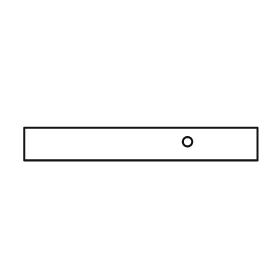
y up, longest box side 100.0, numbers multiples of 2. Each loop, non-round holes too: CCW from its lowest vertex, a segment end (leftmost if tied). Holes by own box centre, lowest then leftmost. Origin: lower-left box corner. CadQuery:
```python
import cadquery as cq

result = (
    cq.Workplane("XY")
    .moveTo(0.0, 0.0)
    .lineTo(100.0, 0.0)
    .lineTo(100.0, 14.0)
    .lineTo(0.0, 14.0)
    .close()
    .moveTo(70.0, 8.0)
    .circle(2.0)
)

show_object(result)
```